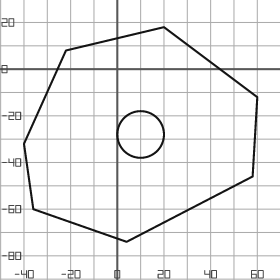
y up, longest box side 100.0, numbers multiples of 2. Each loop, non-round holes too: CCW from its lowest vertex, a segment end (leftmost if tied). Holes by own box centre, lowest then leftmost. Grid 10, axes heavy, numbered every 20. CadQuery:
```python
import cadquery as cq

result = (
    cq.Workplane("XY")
    .moveTo(4.0, -74.0)
    .lineTo(58.0, -46.0)
    .lineTo(60.0, -12.0)
    .lineTo(20.0, 18.0)
    .lineTo(-22.0, 8.0)
    .lineTo(-40.0, -32.0)
    .lineTo(-36.0, -60.0)
    .close()
    .moveTo(10.0, -28.0)
    .circle(10.0)
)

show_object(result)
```